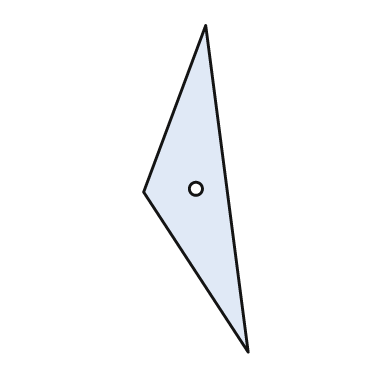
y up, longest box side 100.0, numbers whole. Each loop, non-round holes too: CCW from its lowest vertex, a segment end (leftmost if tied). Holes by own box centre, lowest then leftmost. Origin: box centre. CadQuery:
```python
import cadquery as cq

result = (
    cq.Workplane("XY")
    .moveTo(16.0, -50.0)
    .lineTo(3.0, 50.0)
    .lineTo(-16.0, -1.0)
    .close()
    .moveTo(0.0, 0.0)
    .circle(2.0)
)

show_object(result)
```